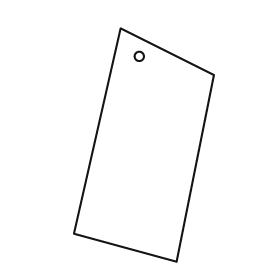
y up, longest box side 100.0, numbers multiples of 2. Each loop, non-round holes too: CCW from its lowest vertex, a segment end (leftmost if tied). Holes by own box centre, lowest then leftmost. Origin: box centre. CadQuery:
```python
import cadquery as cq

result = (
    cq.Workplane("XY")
    .moveTo(14.0, -50.0)
    .lineTo(30.0, 30.0)
    .lineTo(-10.0, 50.0)
    .lineTo(-30.0, -38.0)
    .close()
    .moveTo(-2.0, 38.0)
    .circle(2.0)
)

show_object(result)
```